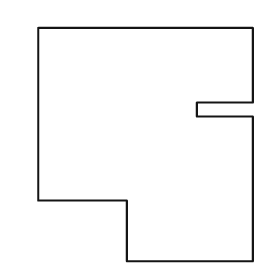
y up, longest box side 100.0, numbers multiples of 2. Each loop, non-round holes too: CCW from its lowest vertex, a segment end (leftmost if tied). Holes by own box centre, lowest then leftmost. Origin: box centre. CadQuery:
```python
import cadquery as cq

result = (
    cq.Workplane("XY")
    .moveTo(-8.0, -50.0)
    .lineTo(46.0, -50.0)
    .lineTo(46.0, 12.0)
    .lineTo(22.0, 12.0)
    .lineTo(22.0, 18.0)
    .lineTo(46.0, 18.0)
    .lineTo(46.0, 50.0)
    .lineTo(-46.0, 50.0)
    .lineTo(-46.0, -24.0)
    .lineTo(-8.0, -24.0)
    .close()
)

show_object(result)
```